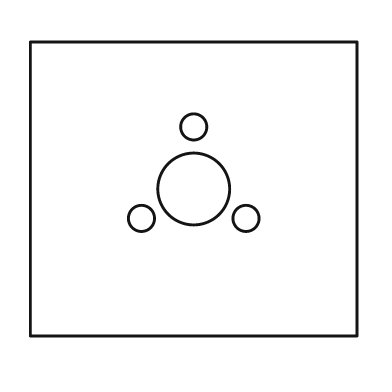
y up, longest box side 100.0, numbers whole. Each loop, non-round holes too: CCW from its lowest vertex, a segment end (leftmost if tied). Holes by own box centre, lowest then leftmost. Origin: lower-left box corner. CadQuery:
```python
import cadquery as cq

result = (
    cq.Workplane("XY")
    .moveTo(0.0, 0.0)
    .lineTo(100.0, 0.0)
    .lineTo(100.0, 90.0)
    .lineTo(0.0, 90.0)
    .close()
    .moveTo(34.0, 36.0)
    .circle(4.0)
    .moveTo(66.0, 36.0)
    .circle(4.0)
    .moveTo(50.0, 45.0)
    .circle(11.0)
    .moveTo(50.0, 64.0)
    .circle(4.0)
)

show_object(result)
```